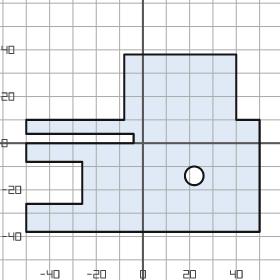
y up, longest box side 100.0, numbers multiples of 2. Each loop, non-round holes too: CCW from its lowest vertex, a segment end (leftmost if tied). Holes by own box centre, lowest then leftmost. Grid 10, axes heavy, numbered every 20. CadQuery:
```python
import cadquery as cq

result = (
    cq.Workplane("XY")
    .moveTo(-50.0, -38.0)
    .lineTo(50.0, -38.0)
    .lineTo(50.0, 10.0)
    .lineTo(40.0, 10.0)
    .lineTo(40.0, 38.0)
    .lineTo(-8.0, 38.0)
    .lineTo(-8.0, 10.0)
    .lineTo(-50.0, 10.0)
    .lineTo(-50.0, 4.0)
    .lineTo(-4.0, 4.0)
    .lineTo(-4.0, 0.0)
    .lineTo(-50.0, 0.0)
    .lineTo(-50.0, -8.0)
    .lineTo(-26.0, -8.0)
    .lineTo(-26.0, -26.0)
    .lineTo(-50.0, -26.0)
    .close()
    .moveTo(22.0, -14.0)
    .circle(4.0)
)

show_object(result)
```